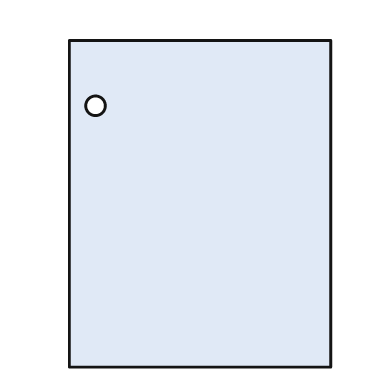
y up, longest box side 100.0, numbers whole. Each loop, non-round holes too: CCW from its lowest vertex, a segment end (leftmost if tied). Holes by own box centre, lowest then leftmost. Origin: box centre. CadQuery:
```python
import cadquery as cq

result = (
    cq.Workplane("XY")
    .moveTo(-40.0, -50.0)
    .lineTo(40.0, -50.0)
    .lineTo(40.0, 50.0)
    .lineTo(-40.0, 50.0)
    .close()
    .moveTo(-32.0, 30.0)
    .circle(3.0)
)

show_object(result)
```